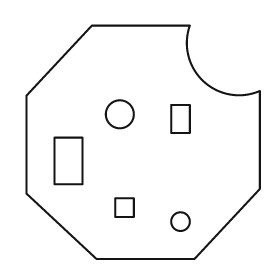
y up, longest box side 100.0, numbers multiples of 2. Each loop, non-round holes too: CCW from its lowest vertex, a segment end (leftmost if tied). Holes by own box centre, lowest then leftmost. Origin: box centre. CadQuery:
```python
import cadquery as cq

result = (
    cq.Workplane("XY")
    .moveTo(-20.0, -50.0)
    .lineTo(22.0, -50.0)
    .lineTo(50.0, -20.0)
    .lineTo(50.0, 22.0)
    .threePointArc((26.0, 26.0), (20.0, 50.0))
    .lineTo(-22.0, 50.0)
    .lineTo(-50.0, 20.0)
    .lineTo(-50.0, -22.0)
    .close()
    .moveTo(16.0, -34.0)
    .circle(4.0)
    .moveTo(-12.0, -32.0)
    .lineTo(-4.0, -32.0)
    .lineTo(-4.0, -24.0)
    .lineTo(-12.0, -24.0)
    .close()
    .moveTo(-38.0, -18.0)
    .lineTo(-26.0, -18.0)
    .lineTo(-26.0, 2.0)
    .lineTo(-38.0, 2.0)
    .close()
    .moveTo(12.0, 4.0)
    .lineTo(20.0, 4.0)
    .lineTo(20.0, 16.0)
    .lineTo(12.0, 16.0)
    .close()
    .moveTo(-10.0, 12.0)
    .circle(6.0)
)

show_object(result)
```